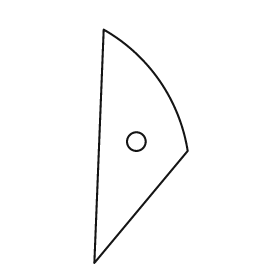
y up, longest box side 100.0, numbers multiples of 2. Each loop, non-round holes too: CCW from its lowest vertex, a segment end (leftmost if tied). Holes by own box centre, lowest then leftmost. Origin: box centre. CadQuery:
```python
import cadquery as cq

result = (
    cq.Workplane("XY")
    .moveTo(-20.0, -50.0)
    .lineTo(20.0, -2.0)
    .threePointArc((8.0, 28.0), (-16.0, 50.0))
    .close()
    .moveTo(-2.0, 2.0)
    .circle(4.0)
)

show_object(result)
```